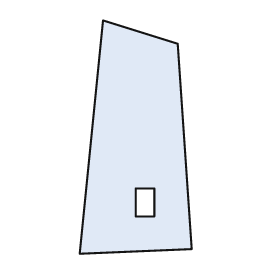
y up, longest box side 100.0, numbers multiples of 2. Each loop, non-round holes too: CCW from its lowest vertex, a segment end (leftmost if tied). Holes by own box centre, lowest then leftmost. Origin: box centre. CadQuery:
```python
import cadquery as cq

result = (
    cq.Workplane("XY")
    .moveTo(-24.0, -50.0)
    .lineTo(24.0, -48.0)
    .lineTo(18.0, 40.0)
    .lineTo(-14.0, 50.0)
    .close()
    .moveTo(0.0, -34.0)
    .lineTo(8.0, -34.0)
    .lineTo(8.0, -22.0)
    .lineTo(0.0, -22.0)
    .close()
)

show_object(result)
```